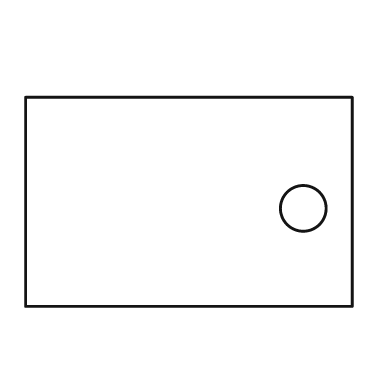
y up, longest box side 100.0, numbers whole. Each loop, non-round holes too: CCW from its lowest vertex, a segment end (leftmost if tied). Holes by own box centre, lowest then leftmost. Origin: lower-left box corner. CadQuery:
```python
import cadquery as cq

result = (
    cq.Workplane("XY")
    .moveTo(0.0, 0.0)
    .lineTo(100.0, 0.0)
    .lineTo(100.0, 64.0)
    .lineTo(0.0, 64.0)
    .close()
    .moveTo(85.0, 30.0)
    .circle(7.0)
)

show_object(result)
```